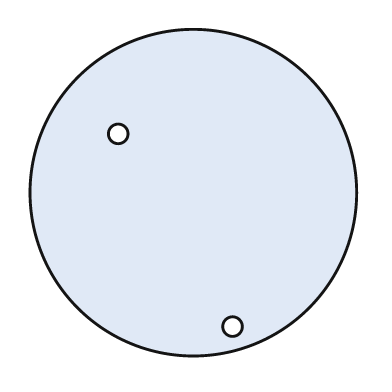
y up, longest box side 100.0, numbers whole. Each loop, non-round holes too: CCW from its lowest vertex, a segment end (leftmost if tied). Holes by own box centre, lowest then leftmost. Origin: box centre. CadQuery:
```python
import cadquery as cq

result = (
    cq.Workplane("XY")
    .moveTo(0.0, 0.0)
    .circle(50.0)
    .moveTo(12.0, -41.0)
    .circle(3.0)
    .moveTo(-23.0, 18.0)
    .circle(3.0)
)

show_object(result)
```